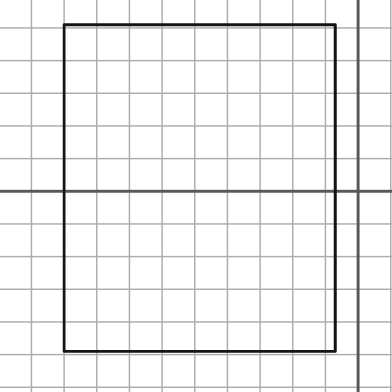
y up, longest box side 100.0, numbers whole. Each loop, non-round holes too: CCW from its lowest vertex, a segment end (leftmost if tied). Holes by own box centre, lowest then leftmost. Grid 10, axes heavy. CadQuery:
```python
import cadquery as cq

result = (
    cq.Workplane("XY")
    .moveTo(-90.0, -49.0)
    .lineTo(-7.0, -49.0)
    .lineTo(-7.0, 51.0)
    .lineTo(-90.0, 51.0)
    .close()
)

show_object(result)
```